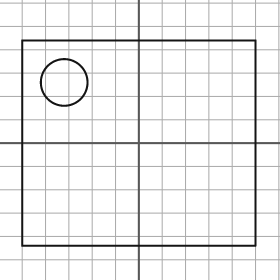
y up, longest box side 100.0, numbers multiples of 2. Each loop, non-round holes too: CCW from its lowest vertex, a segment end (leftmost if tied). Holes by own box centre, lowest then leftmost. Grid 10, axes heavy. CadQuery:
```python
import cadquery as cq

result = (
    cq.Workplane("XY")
    .moveTo(-50.0, -44.0)
    .lineTo(50.0, -44.0)
    .lineTo(50.0, 44.0)
    .lineTo(-50.0, 44.0)
    .close()
    .moveTo(-32.0, 26.0)
    .circle(10.0)
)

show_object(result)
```